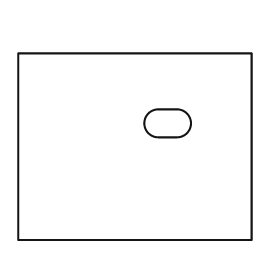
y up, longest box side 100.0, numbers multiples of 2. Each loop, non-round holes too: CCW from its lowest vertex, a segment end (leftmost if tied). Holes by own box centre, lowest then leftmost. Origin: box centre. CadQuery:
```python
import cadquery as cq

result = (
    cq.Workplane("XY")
    .moveTo(-50.0, -40.0)
    .lineTo(50.0, -40.0)
    .lineTo(50.0, 40.0)
    .lineTo(-50.0, 40.0)
    .close()
    .moveTo(10.0, 4.0)
    .lineTo(18.0, 4.0)
    .threePointArc((24.0, 10.0), (18.0, 16.0))
    .lineTo(10.0, 16.0)
    .threePointArc((4.0, 10.0), (10.0, 4.0))
    .close()
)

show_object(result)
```